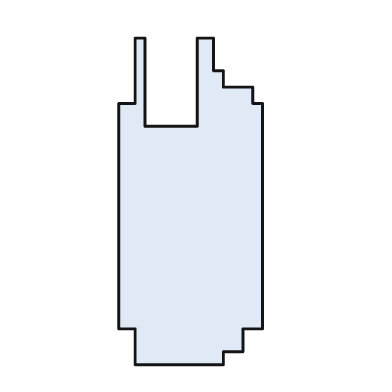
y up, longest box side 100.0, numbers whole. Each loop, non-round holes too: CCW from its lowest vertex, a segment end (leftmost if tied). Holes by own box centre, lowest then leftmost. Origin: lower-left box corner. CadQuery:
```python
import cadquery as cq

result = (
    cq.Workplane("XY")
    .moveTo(5.0, 0.0)
    .lineTo(32.0, 0.0)
    .lineTo(32.0, 4.0)
    .lineTo(38.0, 4.0)
    .lineTo(38.0, 11.0)
    .lineTo(44.0, 11.0)
    .lineTo(44.0, 80.0)
    .lineTo(41.0, 80.0)
    .lineTo(41.0, 85.0)
    .lineTo(32.0, 85.0)
    .lineTo(32.0, 90.0)
    .lineTo(29.0, 90.0)
    .lineTo(29.0, 100.0)
    .lineTo(24.0, 100.0)
    .lineTo(24.0, 73.0)
    .lineTo(8.0, 73.0)
    .lineTo(8.0, 100.0)
    .lineTo(5.0, 100.0)
    .lineTo(5.0, 80.0)
    .lineTo(0.0, 80.0)
    .lineTo(0.0, 11.0)
    .lineTo(5.0, 11.0)
    .close()
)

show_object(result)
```